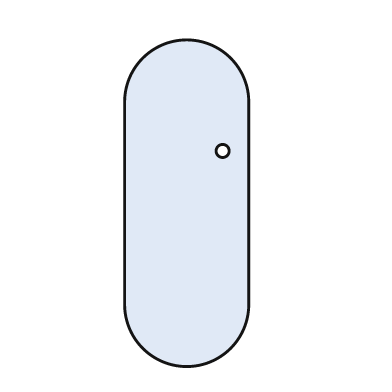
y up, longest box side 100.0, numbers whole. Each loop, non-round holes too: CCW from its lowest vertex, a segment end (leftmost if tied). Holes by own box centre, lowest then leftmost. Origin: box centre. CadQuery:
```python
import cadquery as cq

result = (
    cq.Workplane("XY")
    .moveTo(-19.0, -31.0)
    .threePointArc((0.0, -50.0), (19.0, -31.0))
    .lineTo(19.0, 31.0)
    .threePointArc((0.0, 50.0), (-19.0, 31.0))
    .close()
    .moveTo(11.0, 16.0)
    .circle(2.0)
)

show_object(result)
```